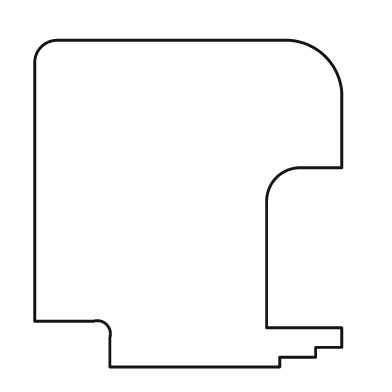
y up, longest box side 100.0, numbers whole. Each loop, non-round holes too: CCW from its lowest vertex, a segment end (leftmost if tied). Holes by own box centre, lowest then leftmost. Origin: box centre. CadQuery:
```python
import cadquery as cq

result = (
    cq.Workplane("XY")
    .moveTo(-24.0, -50.0)
    .lineTo(28.0, -50.0)
    .lineTo(28.0, -47.0)
    .lineTo(39.0, -47.0)
    .lineTo(39.0, -44.0)
    .lineTo(47.0, -44.0)
    .lineTo(47.0, -38.0)
    .lineTo(24.0, -38.0)
    .lineTo(24.0, 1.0)
    .threePointArc((27.0, 8.0), (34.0, 11.0))
    .lineTo(47.0, 11.0)
    .lineTo(47.0, 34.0)
    .threePointArc((42.0, 45.0), (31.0, 50.0))
    .lineTo(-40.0, 50.0)
    .threePointArc((-45.0, 48.0), (-47.0, 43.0))
    .lineTo(-47.0, -36.0)
    .lineTo(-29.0, -36.0)
    .threePointArc((-25.0, -37.0), (-24.0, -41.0))
    .close()
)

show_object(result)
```